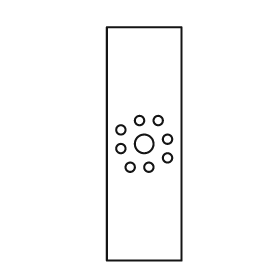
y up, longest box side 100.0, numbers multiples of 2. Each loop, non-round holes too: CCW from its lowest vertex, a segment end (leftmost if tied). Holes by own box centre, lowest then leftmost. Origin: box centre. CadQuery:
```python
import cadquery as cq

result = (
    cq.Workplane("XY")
    .moveTo(-16.0, -50.0)
    .lineTo(16.0, -50.0)
    .lineTo(16.0, 50.0)
    .lineTo(-16.0, 50.0)
    .close()
    .moveTo(-6.0, -10.0)
    .circle(2.0)
    .moveTo(2.0, -10.0)
    .circle(2.0)
    .moveTo(10.0, -6.0)
    .circle(2.0)
    .moveTo(-10.0, -2.0)
    .circle(2.0)
    .moveTo(0.0, 0.0)
    .circle(4.0)
    .moveTo(10.0, 2.0)
    .circle(2.0)
    .moveTo(-10.0, 6.0)
    .circle(2.0)
    .moveTo(-2.0, 10.0)
    .circle(2.0)
    .moveTo(6.0, 10.0)
    .circle(2.0)
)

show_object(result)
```